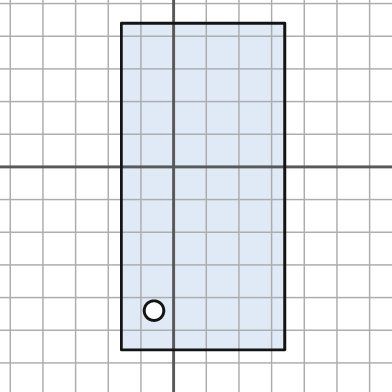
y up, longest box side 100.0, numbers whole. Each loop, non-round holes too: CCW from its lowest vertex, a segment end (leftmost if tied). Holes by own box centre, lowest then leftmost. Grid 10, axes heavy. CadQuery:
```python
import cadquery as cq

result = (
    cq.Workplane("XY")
    .moveTo(-16.0, -56.0)
    .lineTo(34.0, -56.0)
    .lineTo(34.0, 44.0)
    .lineTo(-16.0, 44.0)
    .close()
    .moveTo(-6.0, -44.0)
    .circle(3.0)
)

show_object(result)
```